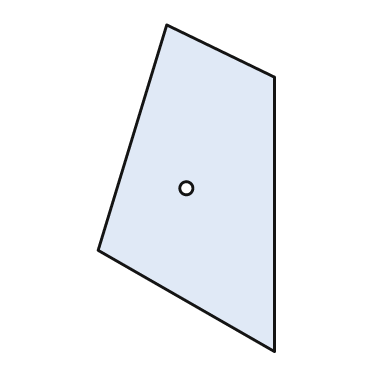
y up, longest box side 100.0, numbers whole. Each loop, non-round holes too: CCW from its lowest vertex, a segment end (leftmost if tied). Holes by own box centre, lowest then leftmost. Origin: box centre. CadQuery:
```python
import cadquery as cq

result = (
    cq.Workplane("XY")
    .moveTo(27.0, -50.0)
    .lineTo(27.0, 34.0)
    .lineTo(-6.0, 50.0)
    .lineTo(-27.0, -19.0)
    .close()
    .moveTo(0.0, 0.0)
    .circle(2.0)
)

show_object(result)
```